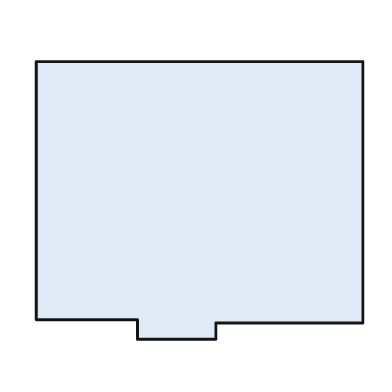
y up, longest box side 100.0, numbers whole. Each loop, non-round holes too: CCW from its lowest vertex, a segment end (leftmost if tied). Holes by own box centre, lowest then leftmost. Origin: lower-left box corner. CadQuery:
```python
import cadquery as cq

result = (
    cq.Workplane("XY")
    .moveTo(31.0, 0.0)
    .lineTo(55.0, 0.0)
    .lineTo(55.0, 5.0)
    .lineTo(100.0, 5.0)
    .lineTo(100.0, 85.0)
    .lineTo(0.0, 85.0)
    .lineTo(0.0, 6.0)
    .lineTo(31.0, 6.0)
    .close()
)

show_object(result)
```